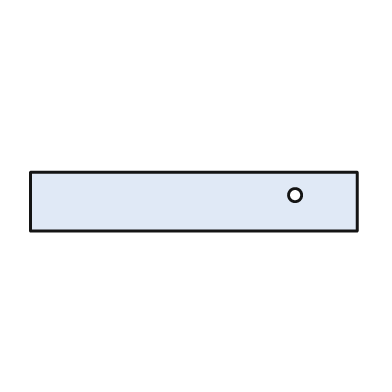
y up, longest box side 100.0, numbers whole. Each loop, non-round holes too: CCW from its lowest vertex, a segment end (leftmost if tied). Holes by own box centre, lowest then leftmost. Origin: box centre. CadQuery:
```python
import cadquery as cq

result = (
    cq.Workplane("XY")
    .moveTo(-50.0, -9.0)
    .lineTo(50.0, -9.0)
    .lineTo(50.0, 9.0)
    .lineTo(-50.0, 9.0)
    .close()
    .moveTo(31.0, 2.0)
    .circle(2.0)
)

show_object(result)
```